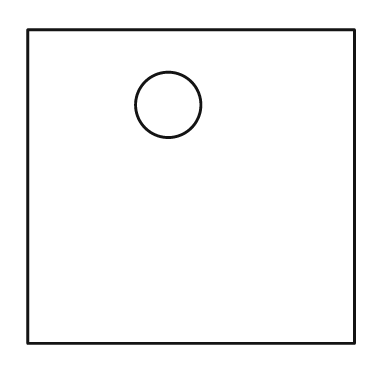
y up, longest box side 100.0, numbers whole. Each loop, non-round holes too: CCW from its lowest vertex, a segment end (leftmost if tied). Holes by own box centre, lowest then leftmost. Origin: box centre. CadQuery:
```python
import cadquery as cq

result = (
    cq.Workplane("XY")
    .moveTo(-50.0, -48.0)
    .lineTo(50.0, -48.0)
    .lineTo(50.0, 48.0)
    .lineTo(-50.0, 48.0)
    .close()
    .moveTo(-7.0, 25.0)
    .circle(10.0)
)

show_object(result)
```